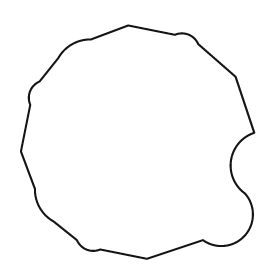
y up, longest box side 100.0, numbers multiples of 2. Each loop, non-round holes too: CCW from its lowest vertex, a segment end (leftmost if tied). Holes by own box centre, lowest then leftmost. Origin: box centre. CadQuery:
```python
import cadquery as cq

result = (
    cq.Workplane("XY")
    .moveTo(4.0, -50.0)
    .lineTo(28.0, -42.0)
    .threePointArc((46.0, -40.0), (46.0, -22.0))
    .threePointArc((40.0, -8.0), (50.0, 4.0))
    .lineTo(42.0, 28.0)
    .lineTo(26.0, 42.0)
    .threePointArc((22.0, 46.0), (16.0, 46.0))
    .lineTo(-4.0, 50.0)
    .lineTo(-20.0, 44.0)
    .threePointArc((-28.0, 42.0), (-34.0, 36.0))
    .lineTo(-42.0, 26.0)
    .threePointArc((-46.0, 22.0), (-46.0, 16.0))
    .lineTo(-50.0, -4.0)
    .lineTo(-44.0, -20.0)
    .threePointArc((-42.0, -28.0), (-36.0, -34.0))
    .lineTo(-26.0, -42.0)
    .threePointArc((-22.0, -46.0), (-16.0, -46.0))
    .close()
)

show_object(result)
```